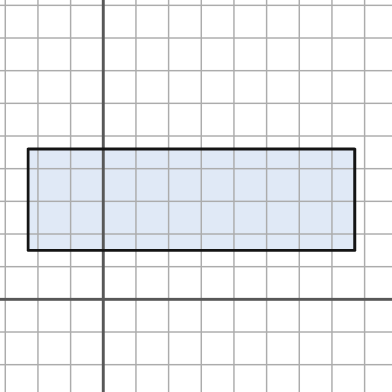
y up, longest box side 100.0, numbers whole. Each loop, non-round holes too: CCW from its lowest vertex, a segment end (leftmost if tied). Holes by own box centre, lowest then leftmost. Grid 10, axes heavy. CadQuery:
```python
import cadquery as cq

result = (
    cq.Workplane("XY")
    .moveTo(-23.0, 15.0)
    .lineTo(77.0, 15.0)
    .lineTo(77.0, 46.0)
    .lineTo(-23.0, 46.0)
    .close()
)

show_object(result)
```